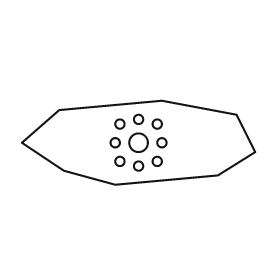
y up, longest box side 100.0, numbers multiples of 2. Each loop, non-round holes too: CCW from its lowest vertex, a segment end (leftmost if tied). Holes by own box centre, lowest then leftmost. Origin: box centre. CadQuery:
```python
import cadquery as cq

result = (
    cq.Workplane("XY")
    .moveTo(-10.0, -18.0)
    .lineTo(34.0, -14.0)
    .lineTo(50.0, -4.0)
    .lineTo(42.0, 12.0)
    .lineTo(10.0, 18.0)
    .lineTo(-34.0, 14.0)
    .lineTo(-50.0, 0.0)
    .lineTo(-32.0, -12.0)
    .close()
    .moveTo(0.0, -10.0)
    .circle(2.0)
    .moveTo(-8.0, -8.0)
    .circle(2.0)
    .moveTo(8.0, -8.0)
    .circle(2.0)
    .moveTo(-10.0, 0.0)
    .circle(2.0)
    .moveTo(0.0, 0.0)
    .circle(4.0)
    .moveTo(10.0, 0.0)
    .circle(2.0)
    .moveTo(-8.0, 8.0)
    .circle(2.0)
    .moveTo(8.0, 8.0)
    .circle(2.0)
    .moveTo(0.0, 10.0)
    .circle(2.0)
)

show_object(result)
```